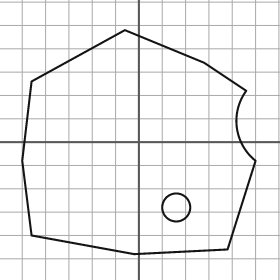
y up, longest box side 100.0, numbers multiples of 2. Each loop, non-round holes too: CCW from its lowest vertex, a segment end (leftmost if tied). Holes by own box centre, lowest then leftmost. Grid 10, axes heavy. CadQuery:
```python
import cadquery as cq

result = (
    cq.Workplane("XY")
    .moveTo(-2.0, -48.0)
    .lineTo(38.0, -46.0)
    .lineTo(50.0, -8.0)
    .threePointArc((42.0, 6.0), (46.0, 22.0))
    .lineTo(28.0, 34.0)
    .lineTo(-6.0, 48.0)
    .lineTo(-46.0, 26.0)
    .lineTo(-50.0, -8.0)
    .lineTo(-46.0, -40.0)
    .close()
    .moveTo(16.0, -28.0)
    .circle(6.0)
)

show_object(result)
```